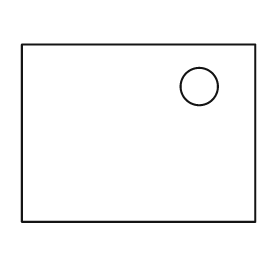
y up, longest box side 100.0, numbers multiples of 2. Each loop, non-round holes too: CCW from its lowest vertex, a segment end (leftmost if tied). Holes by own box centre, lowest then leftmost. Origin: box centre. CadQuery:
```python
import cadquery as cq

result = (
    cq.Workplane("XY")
    .moveTo(-50.0, -38.0)
    .lineTo(50.0, -38.0)
    .lineTo(50.0, 38.0)
    .lineTo(-50.0, 38.0)
    .close()
    .moveTo(26.0, 20.0)
    .circle(8.0)
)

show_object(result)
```